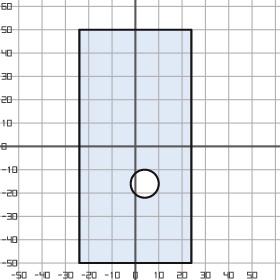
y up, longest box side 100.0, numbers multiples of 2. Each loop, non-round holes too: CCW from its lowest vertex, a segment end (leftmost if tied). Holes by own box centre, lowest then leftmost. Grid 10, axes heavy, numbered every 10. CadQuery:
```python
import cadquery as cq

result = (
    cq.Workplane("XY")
    .moveTo(-24.0, -50.0)
    .lineTo(24.0, -50.0)
    .lineTo(24.0, 50.0)
    .lineTo(-24.0, 50.0)
    .close()
    .moveTo(4.0, -16.0)
    .circle(6.0)
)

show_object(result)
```